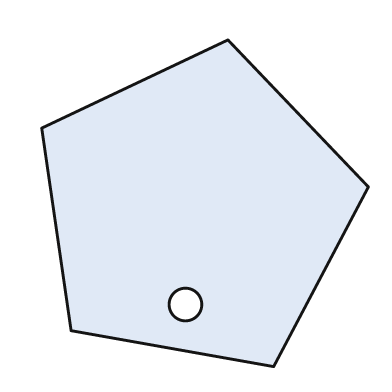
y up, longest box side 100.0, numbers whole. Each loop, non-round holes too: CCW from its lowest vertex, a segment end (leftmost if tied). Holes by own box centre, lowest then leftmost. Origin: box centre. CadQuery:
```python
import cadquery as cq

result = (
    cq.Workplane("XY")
    .moveTo(21.0, -50.0)
    .lineTo(50.0, 5.0)
    .lineTo(7.0, 50.0)
    .lineTo(-50.0, 23.0)
    .lineTo(-41.0, -39.0)
    .close()
    .moveTo(-6.0, -31.0)
    .circle(5.0)
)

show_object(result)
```